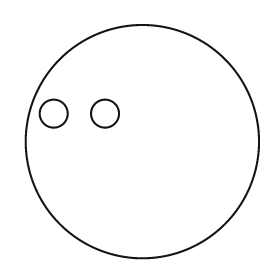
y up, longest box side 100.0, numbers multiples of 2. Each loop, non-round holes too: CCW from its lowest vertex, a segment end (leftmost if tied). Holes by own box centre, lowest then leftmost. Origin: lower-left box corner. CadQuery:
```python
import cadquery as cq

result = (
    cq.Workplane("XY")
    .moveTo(50.0, 50.0)
    .circle(50.0)
    .moveTo(12.0, 62.0)
    .circle(6.0)
    .moveTo(34.0, 62.0)
    .circle(6.0)
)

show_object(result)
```